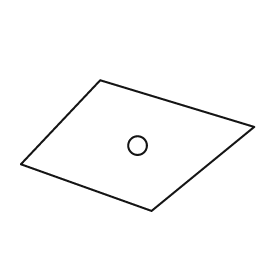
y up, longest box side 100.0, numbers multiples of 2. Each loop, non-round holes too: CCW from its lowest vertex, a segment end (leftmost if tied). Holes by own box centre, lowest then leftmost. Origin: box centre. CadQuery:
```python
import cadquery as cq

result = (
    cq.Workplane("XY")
    .moveTo(6.0, -28.0)
    .lineTo(50.0, 8.0)
    .lineTo(-16.0, 28.0)
    .lineTo(-50.0, -8.0)
    .close()
    .moveTo(0.0, 0.0)
    .circle(4.0)
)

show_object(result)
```